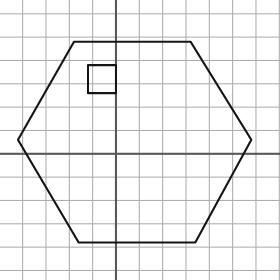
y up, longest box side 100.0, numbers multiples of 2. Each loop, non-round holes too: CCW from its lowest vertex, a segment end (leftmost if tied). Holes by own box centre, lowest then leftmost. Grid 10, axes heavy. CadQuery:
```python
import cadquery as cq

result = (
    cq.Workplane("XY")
    .moveTo(-16.0, -38.0)
    .lineTo(34.0, -38.0)
    .lineTo(58.0, 6.0)
    .lineTo(32.0, 48.0)
    .lineTo(-18.0, 48.0)
    .lineTo(-42.0, 6.0)
    .close()
    .moveTo(-12.0, 26.0)
    .lineTo(0.0, 26.0)
    .lineTo(0.0, 38.0)
    .lineTo(-12.0, 38.0)
    .close()
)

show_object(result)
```